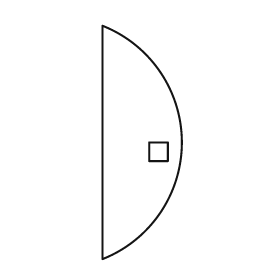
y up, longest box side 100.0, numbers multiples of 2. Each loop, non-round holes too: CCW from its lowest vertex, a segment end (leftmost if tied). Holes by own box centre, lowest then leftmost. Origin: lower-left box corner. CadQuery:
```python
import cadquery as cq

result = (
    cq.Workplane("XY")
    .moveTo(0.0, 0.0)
    .threePointArc((34.0, 50.0), (0.0, 100.0))
    .close()
    .moveTo(20.0, 42.0)
    .lineTo(28.0, 42.0)
    .lineTo(28.0, 50.0)
    .lineTo(20.0, 50.0)
    .close()
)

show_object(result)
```